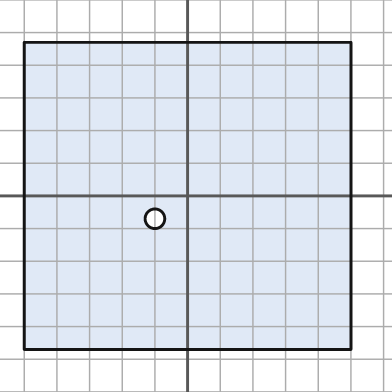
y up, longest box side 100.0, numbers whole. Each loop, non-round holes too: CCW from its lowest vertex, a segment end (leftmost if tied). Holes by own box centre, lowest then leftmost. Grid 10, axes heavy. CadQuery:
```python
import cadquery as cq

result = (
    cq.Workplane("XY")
    .moveTo(-50.0, -47.0)
    .lineTo(50.0, -47.0)
    .lineTo(50.0, 47.0)
    .lineTo(-50.0, 47.0)
    .close()
    .moveTo(-10.0, -7.0)
    .circle(3.0)
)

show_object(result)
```